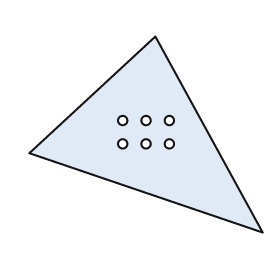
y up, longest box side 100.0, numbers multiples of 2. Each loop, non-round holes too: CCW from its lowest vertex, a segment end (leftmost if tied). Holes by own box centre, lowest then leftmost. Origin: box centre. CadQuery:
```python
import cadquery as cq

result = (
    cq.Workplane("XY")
    .moveTo(50.0, -42.0)
    .lineTo(4.0, 42.0)
    .lineTo(-50.0, -8.0)
    .close()
    .moveTo(-10.0, -4.0)
    .circle(2.0)
    .moveTo(0.0, -4.0)
    .circle(2.0)
    .moveTo(10.0, -4.0)
    .circle(2.0)
    .moveTo(-10.0, 6.0)
    .circle(2.0)
    .moveTo(0.0, 6.0)
    .circle(2.0)
    .moveTo(10.0, 6.0)
    .circle(2.0)
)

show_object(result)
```